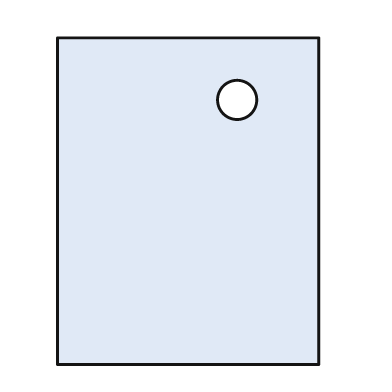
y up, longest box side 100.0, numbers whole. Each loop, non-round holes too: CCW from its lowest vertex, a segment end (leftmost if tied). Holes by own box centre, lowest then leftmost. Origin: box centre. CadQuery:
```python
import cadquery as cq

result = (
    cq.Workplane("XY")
    .moveTo(-40.0, -50.0)
    .lineTo(40.0, -50.0)
    .lineTo(40.0, 50.0)
    .lineTo(-40.0, 50.0)
    .close()
    .moveTo(15.0, 31.0)
    .circle(6.0)
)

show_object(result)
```